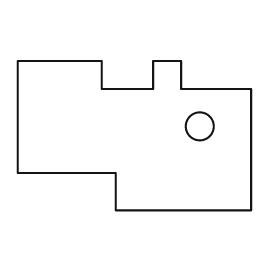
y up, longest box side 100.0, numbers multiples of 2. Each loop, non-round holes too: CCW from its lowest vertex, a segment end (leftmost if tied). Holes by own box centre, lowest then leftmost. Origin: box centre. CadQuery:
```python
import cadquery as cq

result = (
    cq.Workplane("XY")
    .moveTo(-8.0, -32.0)
    .lineTo(50.0, -32.0)
    .lineTo(50.0, 20.0)
    .lineTo(20.0, 20.0)
    .lineTo(20.0, 32.0)
    .lineTo(8.0, 32.0)
    .lineTo(8.0, 20.0)
    .lineTo(-14.0, 20.0)
    .lineTo(-14.0, 32.0)
    .lineTo(-50.0, 32.0)
    .lineTo(-50.0, -16.0)
    .lineTo(-8.0, -16.0)
    .close()
    .moveTo(28.0, 4.0)
    .circle(6.0)
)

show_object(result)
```